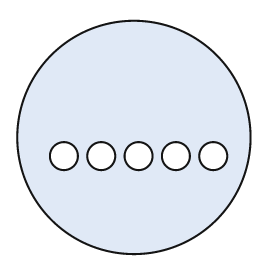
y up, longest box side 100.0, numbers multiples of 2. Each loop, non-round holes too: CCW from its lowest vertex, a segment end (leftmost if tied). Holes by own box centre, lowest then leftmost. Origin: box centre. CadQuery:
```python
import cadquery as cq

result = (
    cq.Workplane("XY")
    .moveTo(0.0, 0.0)
    .circle(50.0)
    .moveTo(-30.0, -8.0)
    .circle(6.0)
    .moveTo(-14.0, -8.0)
    .circle(6.0)
    .moveTo(2.0, -8.0)
    .circle(6.0)
    .moveTo(18.0, -8.0)
    .circle(6.0)
    .moveTo(34.0, -8.0)
    .circle(6.0)
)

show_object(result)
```